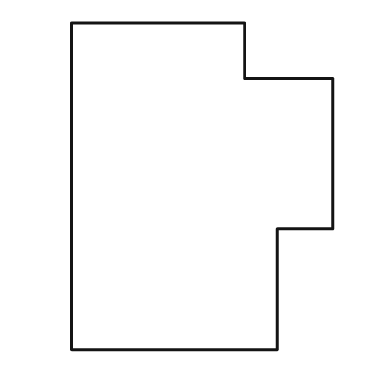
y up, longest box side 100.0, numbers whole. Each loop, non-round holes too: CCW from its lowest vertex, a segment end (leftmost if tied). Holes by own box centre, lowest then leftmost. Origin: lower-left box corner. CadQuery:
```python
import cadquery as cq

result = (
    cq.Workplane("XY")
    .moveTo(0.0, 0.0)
    .lineTo(63.0, 0.0)
    .lineTo(63.0, 37.0)
    .lineTo(80.0, 37.0)
    .lineTo(80.0, 83.0)
    .lineTo(53.0, 83.0)
    .lineTo(53.0, 100.0)
    .lineTo(0.0, 100.0)
    .close()
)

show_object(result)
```